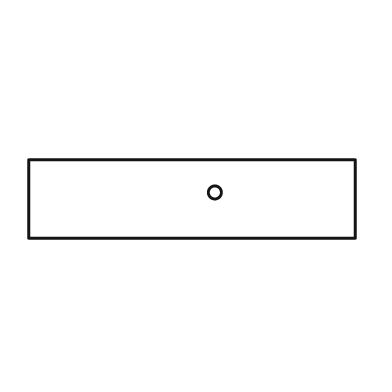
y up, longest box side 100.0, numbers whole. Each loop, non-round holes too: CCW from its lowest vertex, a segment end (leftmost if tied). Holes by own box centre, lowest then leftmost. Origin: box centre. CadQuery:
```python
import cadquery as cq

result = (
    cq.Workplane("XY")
    .moveTo(-50.0, -12.0)
    .lineTo(50.0, -12.0)
    .lineTo(50.0, 12.0)
    .lineTo(-50.0, 12.0)
    .close()
    .moveTo(7.0, 2.0)
    .circle(2.0)
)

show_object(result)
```